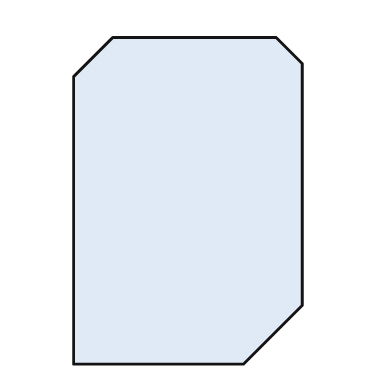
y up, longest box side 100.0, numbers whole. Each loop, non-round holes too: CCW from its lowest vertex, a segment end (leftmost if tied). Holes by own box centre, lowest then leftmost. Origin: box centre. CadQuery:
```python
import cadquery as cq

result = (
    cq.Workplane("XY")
    .moveTo(-35.0, -50.0)
    .lineTo(17.0, -50.0)
    .lineTo(35.0, -32.0)
    .lineTo(35.0, 42.0)
    .lineTo(27.0, 50.0)
    .lineTo(-23.0, 50.0)
    .lineTo(-35.0, 38.0)
    .close()
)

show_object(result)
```